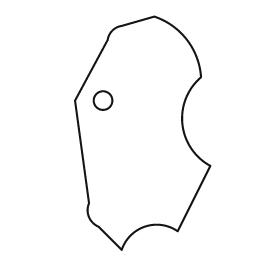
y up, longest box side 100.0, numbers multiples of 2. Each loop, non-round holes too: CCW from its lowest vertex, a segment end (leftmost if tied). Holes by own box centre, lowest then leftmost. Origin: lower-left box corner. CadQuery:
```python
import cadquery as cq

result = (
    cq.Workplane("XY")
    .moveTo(20.0, 0.0)
    .threePointArc((30.0, 10.0), (44.0, 8.0))
    .lineTo(58.0, 36.0)
    .threePointArc((46.0, 54.0), (54.0, 74.0))
    .threePointArc((48.0, 90.0), (34.0, 100.0))
    .lineTo(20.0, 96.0)
    .threePointArc((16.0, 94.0), (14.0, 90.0))
    .lineTo(0.0, 64.0)
    .lineTo(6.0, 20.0)
    .threePointArc((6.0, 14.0), (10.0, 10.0))
    .close()
    .moveTo(12.0, 64.0)
    .circle(4.0)
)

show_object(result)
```